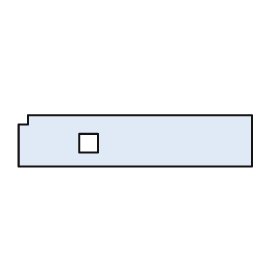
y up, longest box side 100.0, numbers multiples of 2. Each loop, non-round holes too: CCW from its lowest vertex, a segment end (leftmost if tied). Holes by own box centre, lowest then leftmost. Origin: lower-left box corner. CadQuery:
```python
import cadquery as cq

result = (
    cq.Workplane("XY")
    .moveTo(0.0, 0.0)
    .lineTo(100.0, 0.0)
    .lineTo(100.0, 22.0)
    .lineTo(4.0, 22.0)
    .lineTo(4.0, 18.0)
    .lineTo(0.0, 18.0)
    .close()
    .moveTo(26.0, 6.0)
    .lineTo(34.0, 6.0)
    .lineTo(34.0, 14.0)
    .lineTo(26.0, 14.0)
    .close()
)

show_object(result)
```